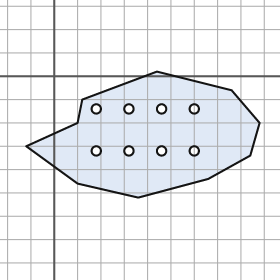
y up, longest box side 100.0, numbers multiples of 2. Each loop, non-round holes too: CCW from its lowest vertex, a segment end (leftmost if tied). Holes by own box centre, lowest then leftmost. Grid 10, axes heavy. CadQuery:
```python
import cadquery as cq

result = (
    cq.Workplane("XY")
    .moveTo(36.0, -52.0)
    .lineTo(66.0, -44.0)
    .lineTo(84.0, -34.0)
    .lineTo(88.0, -20.0)
    .lineTo(76.0, -6.0)
    .lineTo(44.0, 2.0)
    .lineTo(12.0, -10.0)
    .lineTo(10.0, -20.0)
    .lineTo(-12.0, -30.0)
    .lineTo(10.0, -46.0)
    .close()
    .moveTo(18.0, -32.0)
    .circle(2.0)
    .moveTo(32.0, -32.0)
    .circle(2.0)
    .moveTo(46.0, -32.0)
    .circle(2.0)
    .moveTo(60.0, -32.0)
    .circle(2.0)
    .moveTo(18.0, -14.0)
    .circle(2.0)
    .moveTo(32.0, -14.0)
    .circle(2.0)
    .moveTo(46.0, -14.0)
    .circle(2.0)
    .moveTo(60.0, -14.0)
    .circle(2.0)
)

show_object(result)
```